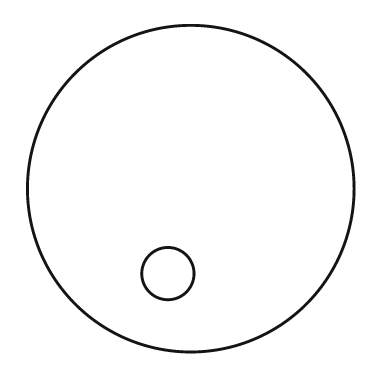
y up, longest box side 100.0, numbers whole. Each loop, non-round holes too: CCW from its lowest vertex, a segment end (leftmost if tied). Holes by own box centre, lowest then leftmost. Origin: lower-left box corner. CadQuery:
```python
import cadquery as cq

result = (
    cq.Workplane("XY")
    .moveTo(50.0, 50.0)
    .circle(50.0)
    .moveTo(43.0, 24.0)
    .circle(8.0)
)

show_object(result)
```